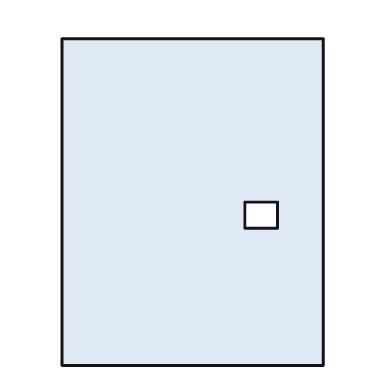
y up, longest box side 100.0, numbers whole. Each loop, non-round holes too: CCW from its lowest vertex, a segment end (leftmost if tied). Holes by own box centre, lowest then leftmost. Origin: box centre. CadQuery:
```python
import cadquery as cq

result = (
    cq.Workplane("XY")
    .moveTo(-40.0, -50.0)
    .lineTo(40.0, -50.0)
    .lineTo(40.0, 50.0)
    .lineTo(-40.0, 50.0)
    .close()
    .moveTo(16.0, -8.0)
    .lineTo(26.0, -8.0)
    .lineTo(26.0, 0.0)
    .lineTo(16.0, 0.0)
    .close()
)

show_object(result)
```